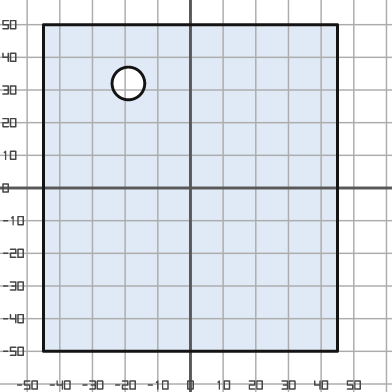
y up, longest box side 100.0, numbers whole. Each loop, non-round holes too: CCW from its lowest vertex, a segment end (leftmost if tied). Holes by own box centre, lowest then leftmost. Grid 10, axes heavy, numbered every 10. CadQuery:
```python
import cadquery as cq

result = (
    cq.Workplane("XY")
    .moveTo(-45.0, -50.0)
    .lineTo(45.0, -50.0)
    .lineTo(45.0, 50.0)
    .lineTo(-45.0, 50.0)
    .close()
    .moveTo(-19.0, 32.0)
    .circle(5.0)
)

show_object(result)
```